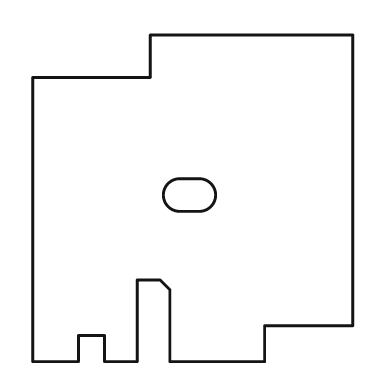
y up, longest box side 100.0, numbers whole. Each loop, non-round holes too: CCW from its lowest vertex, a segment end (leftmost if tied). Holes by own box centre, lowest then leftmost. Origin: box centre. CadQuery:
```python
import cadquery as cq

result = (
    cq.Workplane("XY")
    .moveTo(-49.0, -50.0)
    .lineTo(-35.0, -50.0)
    .lineTo(-35.0, -42.0)
    .lineTo(-27.0, -42.0)
    .lineTo(-27.0, -50.0)
    .lineTo(-17.0, -50.0)
    .lineTo(-17.0, -25.0)
    .lineTo(-10.0, -25.0)
    .lineTo(-7.0, -28.0)
    .lineTo(-7.0, -50.0)
    .lineTo(22.0, -50.0)
    .lineTo(22.0, -39.0)
    .lineTo(49.0, -39.0)
    .lineTo(49.0, 50.0)
    .lineTo(-13.0, 50.0)
    .lineTo(-13.0, 37.0)
    .lineTo(-49.0, 37.0)
    .close()
    .moveTo(-4.0, -4.0)
    .lineTo(2.0, -4.0)
    .threePointArc((7.0, 1.0), (2.0, 6.0))
    .lineTo(-4.0, 6.0)
    .threePointArc((-9.0, 1.0), (-4.0, -4.0))
    .close()
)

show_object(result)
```